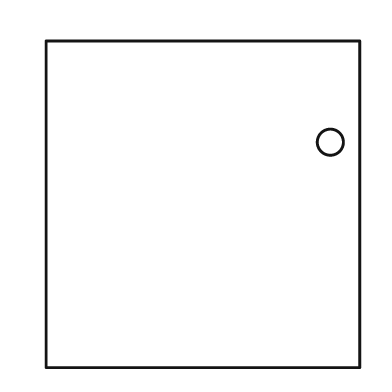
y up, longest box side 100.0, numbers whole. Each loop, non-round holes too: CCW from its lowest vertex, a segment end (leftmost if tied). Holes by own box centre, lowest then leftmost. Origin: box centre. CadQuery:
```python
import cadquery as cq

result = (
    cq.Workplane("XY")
    .moveTo(-48.0, -50.0)
    .lineTo(48.0, -50.0)
    .lineTo(48.0, 50.0)
    .lineTo(-48.0, 50.0)
    .close()
    .moveTo(39.0, 19.0)
    .circle(4.0)
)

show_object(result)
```